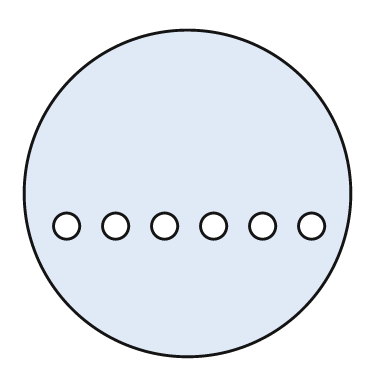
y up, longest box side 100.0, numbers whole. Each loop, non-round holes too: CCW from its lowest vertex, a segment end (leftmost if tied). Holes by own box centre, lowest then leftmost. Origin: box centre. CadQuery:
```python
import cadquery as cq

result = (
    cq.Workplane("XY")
    .moveTo(0.0, 0.0)
    .circle(50.0)
    .moveTo(-37.0, -10.0)
    .circle(4.0)
    .moveTo(-22.0, -10.0)
    .circle(4.0)
    .moveTo(-7.0, -10.0)
    .circle(4.0)
    .moveTo(8.0, -10.0)
    .circle(4.0)
    .moveTo(23.0, -10.0)
    .circle(4.0)
    .moveTo(38.0, -10.0)
    .circle(4.0)
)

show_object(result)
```